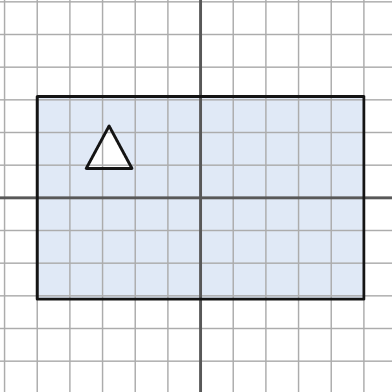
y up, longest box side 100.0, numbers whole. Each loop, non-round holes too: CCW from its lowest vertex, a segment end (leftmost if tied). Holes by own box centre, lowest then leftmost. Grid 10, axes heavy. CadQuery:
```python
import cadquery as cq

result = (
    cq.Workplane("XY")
    .moveTo(-50.0, -31.0)
    .lineTo(50.0, -31.0)
    .lineTo(50.0, 31.0)
    .lineTo(-50.0, 31.0)
    .close()
    .moveTo(-35.0, 9.0)
    .lineTo(-21.0, 9.0)
    .lineTo(-28.0, 22.0)
    .close()
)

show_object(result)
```